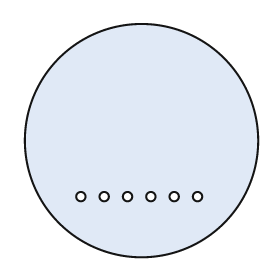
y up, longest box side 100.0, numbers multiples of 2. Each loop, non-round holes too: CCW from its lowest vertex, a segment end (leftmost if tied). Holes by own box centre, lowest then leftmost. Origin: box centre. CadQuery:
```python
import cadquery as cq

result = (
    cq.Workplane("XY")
    .moveTo(0.0, 0.0)
    .circle(50.0)
    .moveTo(-26.0, -24.0)
    .circle(2.0)
    .moveTo(-16.0, -24.0)
    .circle(2.0)
    .moveTo(-6.0, -24.0)
    .circle(2.0)
    .moveTo(4.0, -24.0)
    .circle(2.0)
    .moveTo(14.0, -24.0)
    .circle(2.0)
    .moveTo(24.0, -24.0)
    .circle(2.0)
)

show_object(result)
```